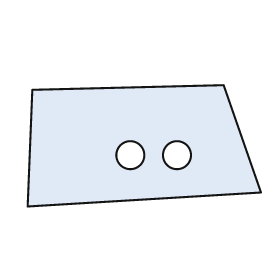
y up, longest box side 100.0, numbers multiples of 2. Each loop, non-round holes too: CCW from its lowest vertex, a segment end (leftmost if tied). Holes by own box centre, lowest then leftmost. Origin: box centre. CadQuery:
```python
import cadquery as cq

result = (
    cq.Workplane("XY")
    .moveTo(-50.0, -26.0)
    .lineTo(50.0, -20.0)
    .lineTo(34.0, 26.0)
    .lineTo(-48.0, 24.0)
    .close()
    .moveTo(-6.0, -4.0)
    .circle(6.0)
    .moveTo(14.0, -4.0)
    .circle(6.0)
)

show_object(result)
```